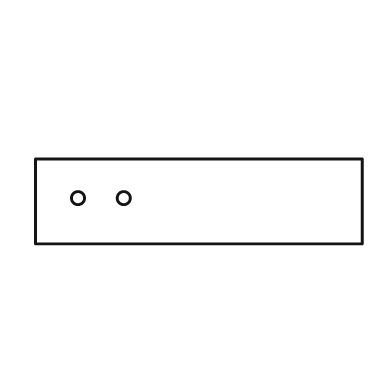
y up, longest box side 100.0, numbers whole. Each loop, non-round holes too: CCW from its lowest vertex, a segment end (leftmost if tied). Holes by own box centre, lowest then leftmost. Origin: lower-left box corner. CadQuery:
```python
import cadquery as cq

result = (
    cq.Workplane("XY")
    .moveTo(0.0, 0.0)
    .lineTo(100.0, 0.0)
    .lineTo(100.0, 26.0)
    .lineTo(0.0, 26.0)
    .close()
    .moveTo(13.0, 14.0)
    .circle(2.0)
    .moveTo(27.0, 14.0)
    .circle(2.0)
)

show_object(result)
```